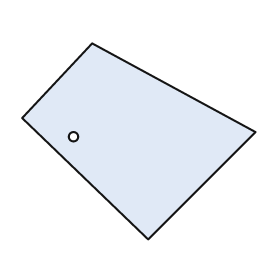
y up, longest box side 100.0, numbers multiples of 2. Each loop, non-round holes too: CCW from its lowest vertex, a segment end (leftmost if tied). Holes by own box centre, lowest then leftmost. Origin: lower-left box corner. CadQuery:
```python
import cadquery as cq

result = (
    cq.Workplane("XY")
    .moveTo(54.0, 0.0)
    .lineTo(100.0, 46.0)
    .lineTo(30.0, 84.0)
    .lineTo(0.0, 52.0)
    .close()
    .moveTo(22.0, 44.0)
    .circle(2.0)
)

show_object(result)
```